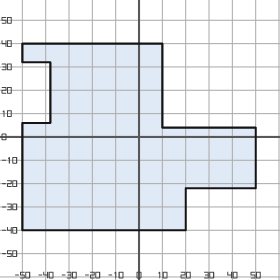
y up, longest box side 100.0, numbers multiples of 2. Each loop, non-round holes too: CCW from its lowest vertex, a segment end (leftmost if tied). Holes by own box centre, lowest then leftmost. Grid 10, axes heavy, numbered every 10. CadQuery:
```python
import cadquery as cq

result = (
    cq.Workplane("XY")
    .moveTo(-50.0, -40.0)
    .lineTo(20.0, -40.0)
    .lineTo(20.0, -22.0)
    .lineTo(50.0, -22.0)
    .lineTo(50.0, 4.0)
    .lineTo(10.0, 4.0)
    .lineTo(10.0, 40.0)
    .lineTo(-50.0, 40.0)
    .lineTo(-50.0, 32.0)
    .lineTo(-38.0, 32.0)
    .lineTo(-38.0, 6.0)
    .lineTo(-50.0, 6.0)
    .close()
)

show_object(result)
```